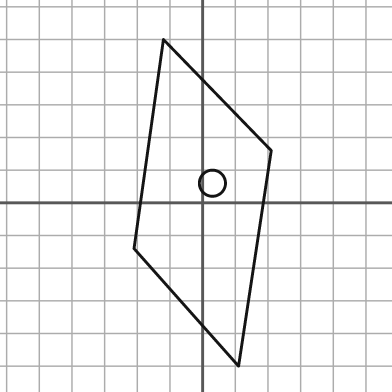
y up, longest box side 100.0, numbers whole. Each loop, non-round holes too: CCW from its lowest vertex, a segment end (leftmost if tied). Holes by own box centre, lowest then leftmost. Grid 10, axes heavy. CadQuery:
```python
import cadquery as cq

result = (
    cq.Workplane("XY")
    .moveTo(11.0, -50.0)
    .lineTo(21.0, 16.0)
    .lineTo(-12.0, 50.0)
    .lineTo(-21.0, -14.0)
    .close()
    .moveTo(3.0, 6.0)
    .circle(4.0)
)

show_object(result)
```